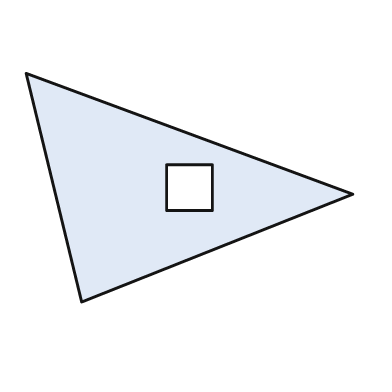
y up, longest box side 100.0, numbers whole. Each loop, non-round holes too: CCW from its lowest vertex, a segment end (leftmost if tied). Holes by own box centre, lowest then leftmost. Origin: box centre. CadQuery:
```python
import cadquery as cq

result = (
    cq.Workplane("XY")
    .moveTo(-33.0, -35.0)
    .lineTo(50.0, -2.0)
    .lineTo(-50.0, 35.0)
    .close()
    .moveTo(-7.0, -7.0)
    .lineTo(7.0, -7.0)
    .lineTo(7.0, 7.0)
    .lineTo(-7.0, 7.0)
    .close()
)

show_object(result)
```